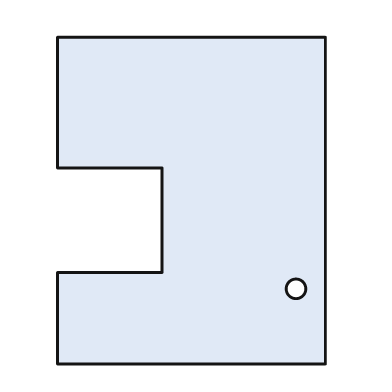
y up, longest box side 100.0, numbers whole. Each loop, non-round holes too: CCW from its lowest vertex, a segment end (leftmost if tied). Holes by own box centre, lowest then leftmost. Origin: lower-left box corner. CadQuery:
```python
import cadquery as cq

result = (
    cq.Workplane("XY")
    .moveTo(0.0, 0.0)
    .lineTo(82.0, 0.0)
    .lineTo(82.0, 100.0)
    .lineTo(0.0, 100.0)
    .lineTo(0.0, 60.0)
    .lineTo(32.0, 60.0)
    .lineTo(32.0, 28.0)
    .lineTo(0.0, 28.0)
    .close()
    .moveTo(73.0, 23.0)
    .circle(3.0)
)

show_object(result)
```